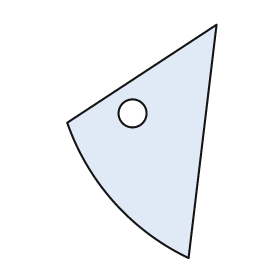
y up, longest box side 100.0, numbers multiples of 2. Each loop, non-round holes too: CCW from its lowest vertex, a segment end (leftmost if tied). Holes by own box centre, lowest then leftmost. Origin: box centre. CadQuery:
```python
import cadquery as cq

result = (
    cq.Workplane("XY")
    .moveTo(20.0, -50.0)
    .lineTo(32.0, 50.0)
    .lineTo(-32.0, 8.0)
    .threePointArc((-12.0, -26.0), (20.0, -50.0))
    .close()
    .moveTo(-4.0, 12.0)
    .circle(6.0)
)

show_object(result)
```